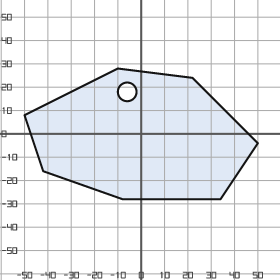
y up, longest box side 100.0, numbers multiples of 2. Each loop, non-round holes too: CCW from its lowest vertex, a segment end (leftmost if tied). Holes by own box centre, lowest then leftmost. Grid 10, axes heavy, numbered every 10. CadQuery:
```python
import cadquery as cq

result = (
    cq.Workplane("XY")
    .moveTo(-8.0, -28.0)
    .lineTo(34.0, -28.0)
    .lineTo(50.0, -4.0)
    .lineTo(22.0, 24.0)
    .lineTo(-10.0, 28.0)
    .lineTo(-50.0, 8.0)
    .lineTo(-42.0, -16.0)
    .close()
    .moveTo(-6.0, 18.0)
    .circle(4.0)
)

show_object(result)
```